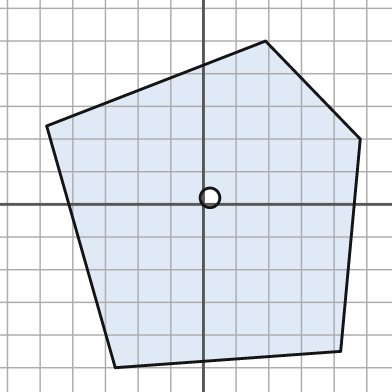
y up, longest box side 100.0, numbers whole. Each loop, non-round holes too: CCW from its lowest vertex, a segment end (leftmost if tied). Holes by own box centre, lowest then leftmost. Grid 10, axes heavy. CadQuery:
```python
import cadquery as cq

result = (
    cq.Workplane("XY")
    .moveTo(-27.0, -50.0)
    .lineTo(42.0, -45.0)
    .lineTo(48.0, 20.0)
    .lineTo(19.0, 50.0)
    .lineTo(-48.0, 24.0)
    .close()
    .moveTo(2.0, 2.0)
    .circle(3.0)
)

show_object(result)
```